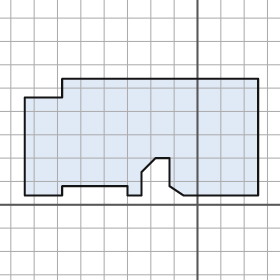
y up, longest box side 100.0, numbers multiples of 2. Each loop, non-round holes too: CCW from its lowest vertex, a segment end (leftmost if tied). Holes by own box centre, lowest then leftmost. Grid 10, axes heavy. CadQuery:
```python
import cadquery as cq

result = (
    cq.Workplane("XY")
    .moveTo(-74.0, 4.0)
    .lineTo(-58.0, 4.0)
    .lineTo(-58.0, 8.0)
    .lineTo(-30.0, 8.0)
    .lineTo(-30.0, 4.0)
    .lineTo(-24.0, 4.0)
    .lineTo(-24.0, 14.0)
    .lineTo(-18.0, 20.0)
    .lineTo(-12.0, 20.0)
    .lineTo(-12.0, 8.0)
    .lineTo(-6.0, 4.0)
    .lineTo(26.0, 4.0)
    .lineTo(26.0, 54.0)
    .lineTo(-58.0, 54.0)
    .lineTo(-58.0, 46.0)
    .lineTo(-74.0, 46.0)
    .close()
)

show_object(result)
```